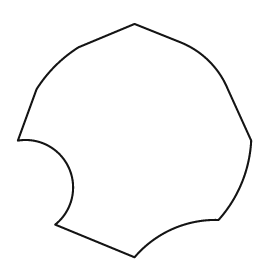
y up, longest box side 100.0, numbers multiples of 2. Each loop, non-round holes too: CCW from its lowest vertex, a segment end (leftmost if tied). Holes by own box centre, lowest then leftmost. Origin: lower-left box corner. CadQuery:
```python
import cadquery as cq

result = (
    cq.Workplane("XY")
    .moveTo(50.0, 0.0)
    .threePointArc((66.0, 12.0), (86.0, 16.0))
    .threePointArc((96.0, 32.0), (100.0, 50.0))
    .lineTo(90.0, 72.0)
    .threePointArc((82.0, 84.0), (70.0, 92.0))
    .lineTo(50.0, 100.0)
    .lineTo(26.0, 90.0)
    .threePointArc((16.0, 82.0), (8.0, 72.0))
    .lineTo(0.0, 50.0)
    .threePointArc((22.0, 38.0), (16.0, 14.0))
    .close()
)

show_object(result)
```